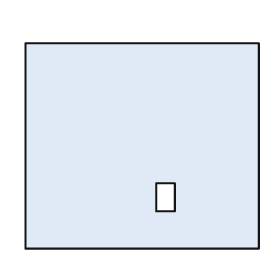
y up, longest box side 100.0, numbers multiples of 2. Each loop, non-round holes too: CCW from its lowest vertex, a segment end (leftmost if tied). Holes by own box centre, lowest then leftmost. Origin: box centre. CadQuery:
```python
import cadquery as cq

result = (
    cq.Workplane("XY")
    .moveTo(-50.0, -44.0)
    .lineTo(50.0, -44.0)
    .lineTo(50.0, 44.0)
    .lineTo(-50.0, 44.0)
    .close()
    .moveTo(6.0, -28.0)
    .lineTo(14.0, -28.0)
    .lineTo(14.0, -16.0)
    .lineTo(6.0, -16.0)
    .close()
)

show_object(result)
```